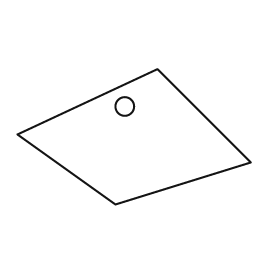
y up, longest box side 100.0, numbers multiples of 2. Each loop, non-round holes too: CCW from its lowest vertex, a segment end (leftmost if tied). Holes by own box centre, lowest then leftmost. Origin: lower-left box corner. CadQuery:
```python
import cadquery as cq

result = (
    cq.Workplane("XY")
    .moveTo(42.0, 0.0)
    .lineTo(100.0, 18.0)
    .lineTo(60.0, 58.0)
    .lineTo(0.0, 30.0)
    .close()
    .moveTo(46.0, 42.0)
    .circle(4.0)
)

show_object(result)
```